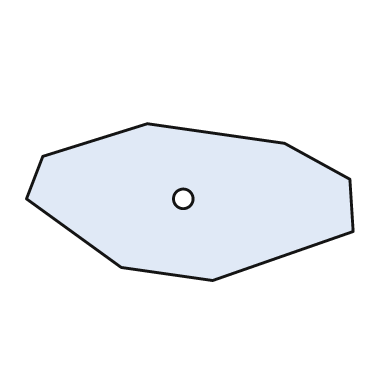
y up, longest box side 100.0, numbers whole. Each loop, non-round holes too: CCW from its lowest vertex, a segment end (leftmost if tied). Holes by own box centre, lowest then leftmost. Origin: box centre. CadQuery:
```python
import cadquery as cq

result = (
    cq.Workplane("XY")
    .moveTo(7.0, -24.0)
    .lineTo(50.0, -9.0)
    .lineTo(49.0, 7.0)
    .lineTo(29.0, 18.0)
    .lineTo(-13.0, 24.0)
    .lineTo(-45.0, 14.0)
    .lineTo(-50.0, 1.0)
    .lineTo(-21.0, -20.0)
    .close()
    .moveTo(-2.0, 1.0)
    .circle(3.0)
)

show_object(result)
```